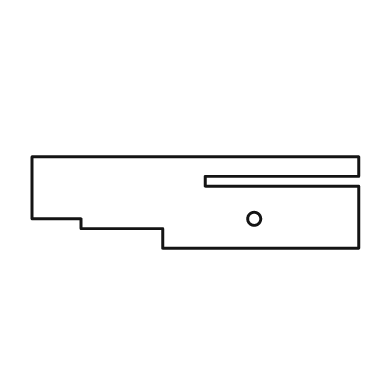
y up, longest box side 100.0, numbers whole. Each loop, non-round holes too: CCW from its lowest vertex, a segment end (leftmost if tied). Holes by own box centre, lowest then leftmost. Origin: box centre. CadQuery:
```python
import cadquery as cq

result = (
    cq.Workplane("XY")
    .moveTo(-10.0, -14.0)
    .lineTo(50.0, -14.0)
    .lineTo(50.0, 5.0)
    .lineTo(3.0, 5.0)
    .lineTo(3.0, 8.0)
    .lineTo(50.0, 8.0)
    .lineTo(50.0, 14.0)
    .lineTo(-50.0, 14.0)
    .lineTo(-50.0, -5.0)
    .lineTo(-35.0, -5.0)
    .lineTo(-35.0, -8.0)
    .lineTo(-10.0, -8.0)
    .close()
    .moveTo(18.0, -5.0)
    .circle(2.0)
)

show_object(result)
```